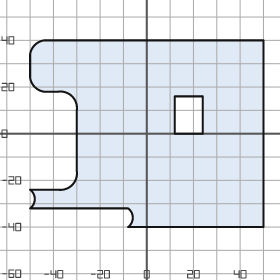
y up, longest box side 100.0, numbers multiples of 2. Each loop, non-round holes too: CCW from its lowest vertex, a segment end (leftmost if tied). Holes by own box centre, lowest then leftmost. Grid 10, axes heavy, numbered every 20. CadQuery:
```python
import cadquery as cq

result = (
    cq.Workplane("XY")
    .moveTo(-8.0, -40.0)
    .lineTo(50.0, -40.0)
    .lineTo(50.0, 40.0)
    .lineTo(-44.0, 40.0)
    .threePointArc((-48.0, 38.0), (-50.0, 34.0))
    .lineTo(-50.0, 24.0)
    .threePointArc((-48.0, 20.0), (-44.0, 18.0))
    .lineTo(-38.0, 18.0)
    .threePointArc((-32.0, 16.0), (-30.0, 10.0))
    .lineTo(-30.0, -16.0)
    .threePointArc((-32.0, -22.0), (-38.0, -24.0))
    .lineTo(-50.0, -24.0)
    .threePointArc((-48.0, -28.0), (-50.0, -32.0))
    .lineTo(-8.0, -32.0)
    .threePointArc((-6.0, -36.0), (-8.0, -40.0))
    .close()
    .moveTo(12.0, 0.0)
    .lineTo(24.0, 0.0)
    .lineTo(24.0, 16.0)
    .lineTo(12.0, 16.0)
    .close()
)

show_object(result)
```